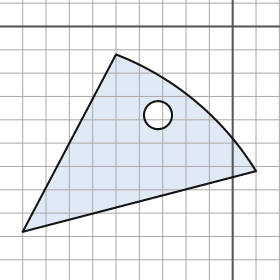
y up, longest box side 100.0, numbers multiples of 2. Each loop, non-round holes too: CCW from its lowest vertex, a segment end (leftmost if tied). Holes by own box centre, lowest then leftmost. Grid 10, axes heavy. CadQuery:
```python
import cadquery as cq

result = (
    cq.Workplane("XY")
    .moveTo(-90.0, -88.0)
    .lineTo(10.0, -62.0)
    .threePointArc((-16.0, -32.0), (-50.0, -12.0))
    .close()
    .moveTo(-32.0, -38.0)
    .circle(6.0)
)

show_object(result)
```